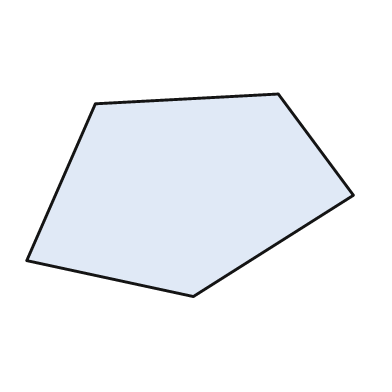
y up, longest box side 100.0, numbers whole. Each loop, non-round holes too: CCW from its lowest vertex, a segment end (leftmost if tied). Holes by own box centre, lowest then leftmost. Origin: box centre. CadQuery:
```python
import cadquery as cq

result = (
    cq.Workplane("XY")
    .moveTo(1.0, -31.0)
    .lineTo(50.0, 0.0)
    .lineTo(27.0, 31.0)
    .lineTo(-29.0, 28.0)
    .lineTo(-50.0, -20.0)
    .close()
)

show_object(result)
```